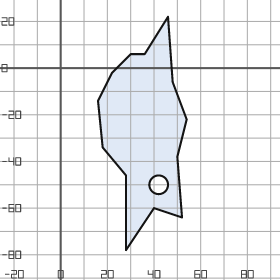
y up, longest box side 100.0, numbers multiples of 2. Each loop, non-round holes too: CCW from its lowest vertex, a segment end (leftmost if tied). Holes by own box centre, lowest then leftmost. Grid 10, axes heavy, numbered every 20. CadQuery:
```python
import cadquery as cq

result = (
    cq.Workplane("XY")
    .moveTo(28.0, -78.0)
    .lineTo(40.0, -60.0)
    .lineTo(52.0, -64.0)
    .lineTo(50.0, -38.0)
    .lineTo(54.0, -22.0)
    .lineTo(48.0, -6.0)
    .lineTo(46.0, 22.0)
    .lineTo(36.0, 6.0)
    .lineTo(30.0, 6.0)
    .lineTo(22.0, -2.0)
    .lineTo(16.0, -14.0)
    .lineTo(18.0, -34.0)
    .lineTo(28.0, -46.0)
    .close()
    .moveTo(42.0, -50.0)
    .circle(4.0)
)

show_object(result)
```